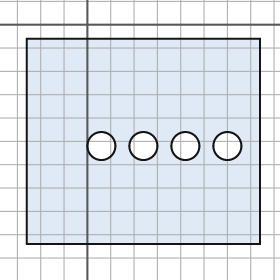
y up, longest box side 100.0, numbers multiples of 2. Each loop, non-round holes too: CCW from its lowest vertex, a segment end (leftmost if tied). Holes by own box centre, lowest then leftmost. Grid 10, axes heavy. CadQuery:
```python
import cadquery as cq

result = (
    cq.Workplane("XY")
    .moveTo(-26.0, -94.0)
    .lineTo(74.0, -94.0)
    .lineTo(74.0, -6.0)
    .lineTo(-26.0, -6.0)
    .close()
    .moveTo(6.0, -52.0)
    .circle(6.0)
    .moveTo(24.0, -52.0)
    .circle(6.0)
    .moveTo(42.0, -52.0)
    .circle(6.0)
    .moveTo(60.0, -52.0)
    .circle(6.0)
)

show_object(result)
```